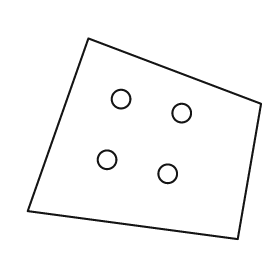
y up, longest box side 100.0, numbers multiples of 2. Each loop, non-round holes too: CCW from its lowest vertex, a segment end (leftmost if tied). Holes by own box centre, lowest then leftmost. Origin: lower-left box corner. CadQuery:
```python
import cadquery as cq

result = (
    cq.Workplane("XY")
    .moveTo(90.0, 0.0)
    .lineTo(100.0, 58.0)
    .lineTo(26.0, 86.0)
    .lineTo(0.0, 12.0)
    .close()
    .moveTo(60.0, 28.0)
    .circle(4.0)
    .moveTo(34.0, 34.0)
    .circle(4.0)
    .moveTo(66.0, 54.0)
    .circle(4.0)
    .moveTo(40.0, 60.0)
    .circle(4.0)
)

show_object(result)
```